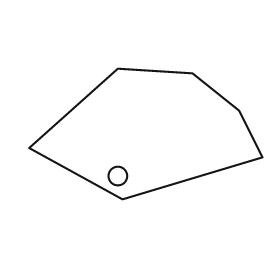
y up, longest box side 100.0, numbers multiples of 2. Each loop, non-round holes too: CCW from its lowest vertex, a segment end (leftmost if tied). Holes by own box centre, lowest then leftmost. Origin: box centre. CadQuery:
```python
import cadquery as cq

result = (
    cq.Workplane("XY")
    .moveTo(-10.0, -28.0)
    .lineTo(50.0, -10.0)
    .lineTo(40.0, 10.0)
    .lineTo(20.0, 26.0)
    .lineTo(-12.0, 28.0)
    .lineTo(-50.0, -6.0)
    .close()
    .moveTo(-12.0, -18.0)
    .circle(4.0)
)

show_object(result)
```